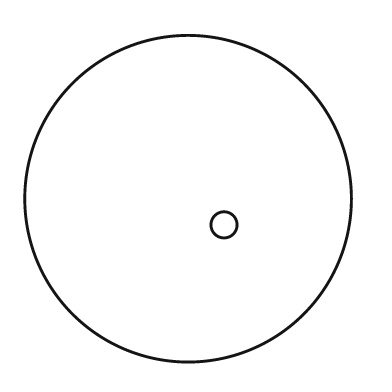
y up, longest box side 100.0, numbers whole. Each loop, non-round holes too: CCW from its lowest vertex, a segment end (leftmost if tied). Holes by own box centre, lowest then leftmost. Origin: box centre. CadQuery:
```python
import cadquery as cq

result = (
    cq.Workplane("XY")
    .moveTo(0.0, 0.0)
    .circle(50.0)
    .moveTo(11.0, -8.0)
    .circle(4.0)
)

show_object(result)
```